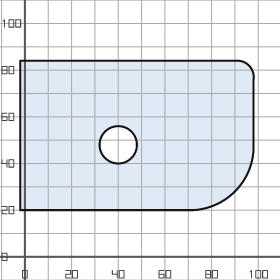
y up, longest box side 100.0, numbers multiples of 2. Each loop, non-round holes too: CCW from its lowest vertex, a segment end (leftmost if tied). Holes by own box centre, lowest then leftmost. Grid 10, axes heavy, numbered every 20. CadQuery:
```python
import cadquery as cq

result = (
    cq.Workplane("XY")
    .moveTo(-2.0, 20.0)
    .lineTo(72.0, 20.0)
    .threePointArc((90.0, 28.0), (98.0, 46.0))
    .lineTo(98.0, 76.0)
    .threePointArc((96.0, 82.0), (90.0, 84.0))
    .lineTo(-2.0, 84.0)
    .close()
    .moveTo(40.0, 48.0)
    .circle(8.0)
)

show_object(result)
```